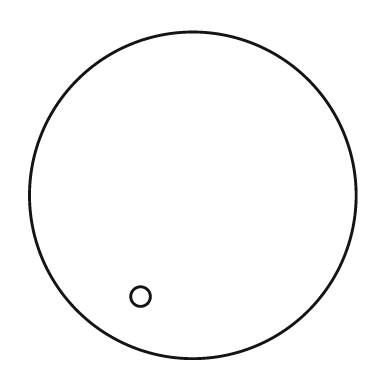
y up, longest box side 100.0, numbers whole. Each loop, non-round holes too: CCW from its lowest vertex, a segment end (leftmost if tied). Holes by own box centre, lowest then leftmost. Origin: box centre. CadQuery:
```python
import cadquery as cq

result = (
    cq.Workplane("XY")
    .moveTo(0.0, 0.0)
    .circle(50.0)
    .moveTo(-16.0, -31.0)
    .circle(3.0)
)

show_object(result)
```